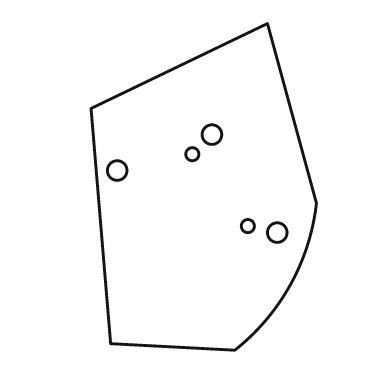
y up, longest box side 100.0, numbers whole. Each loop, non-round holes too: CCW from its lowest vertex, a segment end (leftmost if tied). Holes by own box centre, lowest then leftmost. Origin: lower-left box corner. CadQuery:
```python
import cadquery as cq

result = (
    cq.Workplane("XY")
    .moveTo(44.0, 0.0)
    .threePointArc((61.0, 20.0), (69.0, 45.0))
    .lineTo(54.0, 100.0)
    .lineTo(0.0, 74.0)
    .lineTo(6.0, 2.0)
    .close()
    .moveTo(57.0, 36.0)
    .circle(3.0)
    .moveTo(48.0, 38.0)
    .circle(2.0)
    .moveTo(8.0, 55.0)
    .circle(3.0)
    .moveTo(31.0, 60.0)
    .circle(2.0)
    .moveTo(37.0, 66.0)
    .circle(3.0)
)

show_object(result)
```